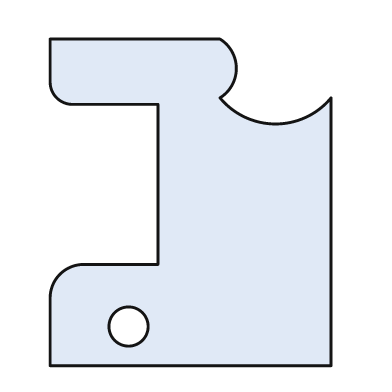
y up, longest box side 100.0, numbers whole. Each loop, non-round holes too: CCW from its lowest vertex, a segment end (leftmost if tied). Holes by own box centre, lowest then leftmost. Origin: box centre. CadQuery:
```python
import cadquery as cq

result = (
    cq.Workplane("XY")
    .moveTo(-43.0, -50.0)
    .lineTo(43.0, -50.0)
    .lineTo(43.0, 32.0)
    .threePointArc((26.0, 24.0), (9.0, 32.0))
    .threePointArc((14.0, 41.0), (9.0, 50.0))
    .lineTo(-43.0, 50.0)
    .lineTo(-43.0, 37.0)
    .threePointArc((-41.0, 32.0), (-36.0, 30.0))
    .lineTo(-10.0, 30.0)
    .lineTo(-10.0, -19.0)
    .lineTo(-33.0, -19.0)
    .threePointArc((-40.0, -22.0), (-43.0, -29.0))
    .close()
    .moveTo(-19.0, -38.0)
    .circle(6.0)
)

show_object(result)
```